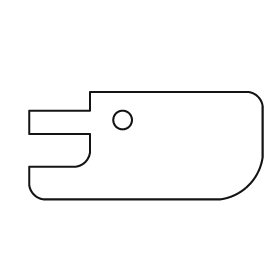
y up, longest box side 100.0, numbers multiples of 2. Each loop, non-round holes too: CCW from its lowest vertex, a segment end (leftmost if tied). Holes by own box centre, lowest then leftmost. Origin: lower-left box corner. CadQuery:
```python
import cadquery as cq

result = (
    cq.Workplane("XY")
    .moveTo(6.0, 0.0)
    .lineTo(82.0, 0.0)
    .threePointArc((94.0, 6.0), (100.0, 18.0))
    .lineTo(100.0, 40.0)
    .threePointArc((98.0, 44.0), (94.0, 46.0))
    .lineTo(26.0, 46.0)
    .lineTo(26.0, 38.0)
    .lineTo(0.0, 38.0)
    .lineTo(0.0, 28.0)
    .lineTo(26.0, 28.0)
    .lineTo(26.0, 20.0)
    .threePointArc((24.0, 16.0), (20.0, 14.0))
    .lineTo(0.0, 14.0)
    .lineTo(0.0, 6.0)
    .threePointArc((2.0, 2.0), (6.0, 0.0))
    .close()
    .moveTo(40.0, 34.0)
    .circle(4.0)
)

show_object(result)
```